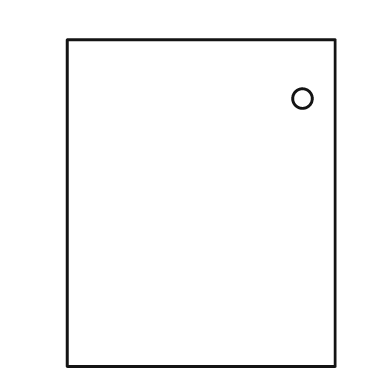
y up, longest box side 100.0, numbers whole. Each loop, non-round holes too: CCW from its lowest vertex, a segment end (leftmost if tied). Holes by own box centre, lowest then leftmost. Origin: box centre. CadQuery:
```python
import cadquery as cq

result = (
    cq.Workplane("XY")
    .moveTo(-41.0, -50.0)
    .lineTo(41.0, -50.0)
    .lineTo(41.0, 50.0)
    .lineTo(-41.0, 50.0)
    .close()
    .moveTo(31.0, 32.0)
    .circle(3.0)
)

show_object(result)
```